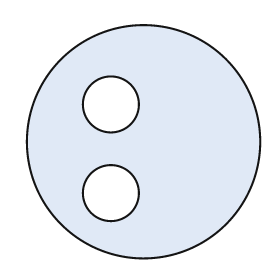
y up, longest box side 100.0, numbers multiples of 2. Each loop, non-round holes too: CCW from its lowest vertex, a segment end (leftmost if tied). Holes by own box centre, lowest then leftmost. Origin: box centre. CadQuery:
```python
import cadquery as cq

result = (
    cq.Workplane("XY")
    .moveTo(0.0, 0.0)
    .circle(50.0)
    .moveTo(-14.0, -22.0)
    .circle(12.0)
    .moveTo(-14.0, 16.0)
    .circle(12.0)
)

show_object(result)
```